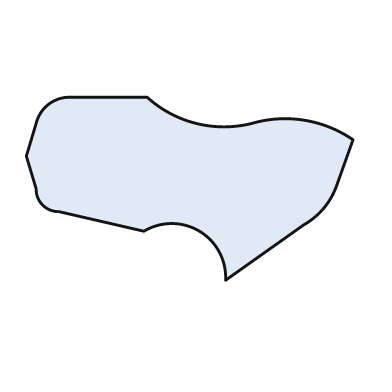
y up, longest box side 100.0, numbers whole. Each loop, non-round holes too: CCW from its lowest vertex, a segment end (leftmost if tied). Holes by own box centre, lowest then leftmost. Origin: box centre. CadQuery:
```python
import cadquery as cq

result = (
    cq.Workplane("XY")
    .moveTo(11.0, -28.0)
    .lineTo(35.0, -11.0)
    .threePointArc((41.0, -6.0), (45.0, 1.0))
    .lineTo(50.0, 15.0)
    .threePointArc((35.0, 21.0), (19.0, 20.0))
    .threePointArc((2.0, 20.0), (-13.0, 28.0))
    .lineTo(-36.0, 28.0)
    .threePointArc((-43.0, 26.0), (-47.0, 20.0))
    .lineTo(-50.0, 10.0)
    .lineTo(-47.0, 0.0)
    .threePointArc((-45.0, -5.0), (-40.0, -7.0))
    .lineTo(-14.0, -13.0)
    .threePointArc((3.0, -13.0), (11.0, -28.0))
    .close()
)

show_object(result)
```